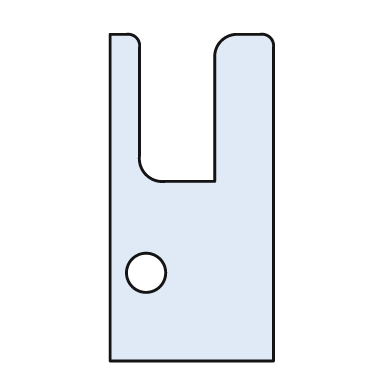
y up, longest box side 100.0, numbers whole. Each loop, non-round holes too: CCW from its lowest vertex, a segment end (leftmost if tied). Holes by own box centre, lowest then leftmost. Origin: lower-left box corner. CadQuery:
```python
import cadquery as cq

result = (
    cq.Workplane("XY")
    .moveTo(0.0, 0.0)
    .lineTo(50.0, 0.0)
    .lineTo(50.0, 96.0)
    .threePointArc((49.0, 99.0), (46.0, 100.0))
    .lineTo(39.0, 100.0)
    .threePointArc((34.0, 98.0), (32.0, 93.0))
    .lineTo(32.0, 55.0)
    .lineTo(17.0, 55.0)
    .threePointArc((11.0, 57.0), (9.0, 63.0))
    .lineTo(9.0, 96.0)
    .threePointArc((8.0, 99.0), (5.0, 100.0))
    .lineTo(0.0, 100.0)
    .close()
    .moveTo(11.0, 27.0)
    .circle(6.0)
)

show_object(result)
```